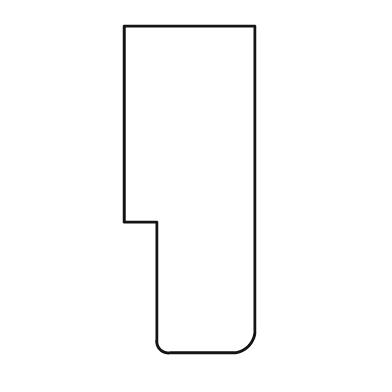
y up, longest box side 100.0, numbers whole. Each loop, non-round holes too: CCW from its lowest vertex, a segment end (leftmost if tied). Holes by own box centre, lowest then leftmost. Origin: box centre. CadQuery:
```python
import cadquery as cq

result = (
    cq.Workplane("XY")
    .moveTo(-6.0, -50.0)
    .lineTo(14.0, -50.0)
    .threePointArc((18.0, -48.0), (20.0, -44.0))
    .lineTo(20.0, 50.0)
    .lineTo(-20.0, 50.0)
    .lineTo(-20.0, -10.0)
    .lineTo(-10.0, -10.0)
    .lineTo(-10.0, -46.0)
    .threePointArc((-9.0, -49.0), (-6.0, -50.0))
    .close()
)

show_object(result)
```